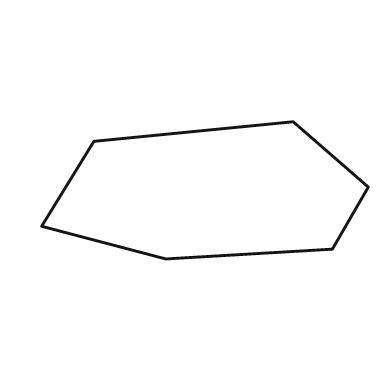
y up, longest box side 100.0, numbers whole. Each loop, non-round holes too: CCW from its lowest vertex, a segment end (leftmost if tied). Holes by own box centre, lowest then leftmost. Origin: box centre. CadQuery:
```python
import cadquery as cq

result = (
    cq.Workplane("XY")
    .moveTo(-12.0, -21.0)
    .lineTo(39.0, -18.0)
    .lineTo(50.0, 1.0)
    .lineTo(27.0, 21.0)
    .lineTo(-34.0, 15.0)
    .lineTo(-50.0, -11.0)
    .close()
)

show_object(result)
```